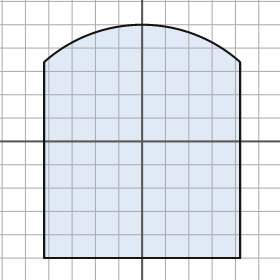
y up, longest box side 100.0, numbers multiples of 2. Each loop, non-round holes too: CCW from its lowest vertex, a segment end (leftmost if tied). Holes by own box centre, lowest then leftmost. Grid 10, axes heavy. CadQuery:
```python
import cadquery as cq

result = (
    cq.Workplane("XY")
    .moveTo(-42.0, -50.0)
    .lineTo(42.0, -50.0)
    .lineTo(42.0, 34.0)
    .threePointArc((0.0, 50.0), (-42.0, 34.0))
    .close()
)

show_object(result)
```